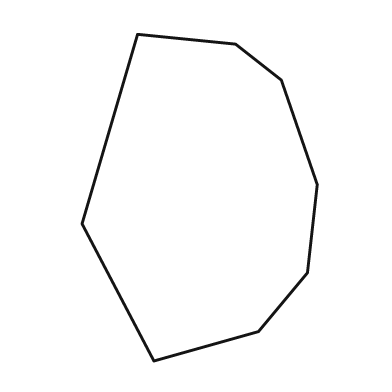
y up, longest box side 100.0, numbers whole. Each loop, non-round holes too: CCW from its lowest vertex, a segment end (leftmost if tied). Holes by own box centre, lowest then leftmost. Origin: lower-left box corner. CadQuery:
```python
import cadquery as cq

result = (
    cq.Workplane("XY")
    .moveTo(22.0, 0.0)
    .lineTo(54.0, 9.0)
    .lineTo(69.0, 27.0)
    .lineTo(72.0, 54.0)
    .lineTo(61.0, 86.0)
    .lineTo(47.0, 97.0)
    .lineTo(17.0, 100.0)
    .lineTo(0.0, 42.0)
    .close()
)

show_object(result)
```